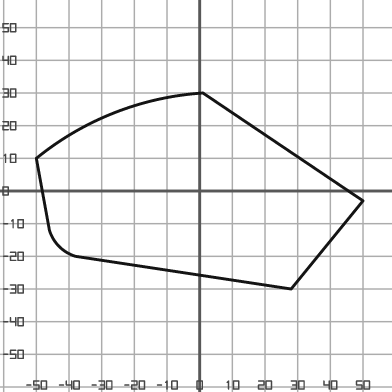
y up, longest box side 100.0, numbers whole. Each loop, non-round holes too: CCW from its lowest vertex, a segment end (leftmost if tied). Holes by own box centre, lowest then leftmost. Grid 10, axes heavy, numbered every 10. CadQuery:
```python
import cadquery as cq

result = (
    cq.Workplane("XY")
    .moveTo(28.0, -30.0)
    .lineTo(50.0, -3.0)
    .lineTo(1.0, 30.0)
    .threePointArc((-26.0, 24.0), (-50.0, 10.0))
    .lineTo(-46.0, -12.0)
    .threePointArc((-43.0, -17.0), (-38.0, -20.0))
    .close()
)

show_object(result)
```